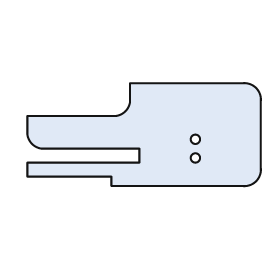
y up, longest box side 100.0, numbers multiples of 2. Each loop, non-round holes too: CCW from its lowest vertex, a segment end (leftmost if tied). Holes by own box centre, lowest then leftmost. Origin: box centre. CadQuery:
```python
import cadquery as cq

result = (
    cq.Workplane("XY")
    .moveTo(-14.0, -22.0)
    .lineTo(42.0, -22.0)
    .threePointArc((48.0, -20.0), (50.0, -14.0))
    .lineTo(50.0, 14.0)
    .threePointArc((48.0, 20.0), (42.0, 22.0))
    .lineTo(-6.0, 22.0)
    .lineTo(-6.0, 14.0)
    .threePointArc((-8.0, 10.0), (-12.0, 8.0))
    .lineTo(-50.0, 8.0)
    .lineTo(-50.0, 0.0)
    .threePointArc((-48.0, -4.0), (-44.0, -6.0))
    .lineTo(-2.0, -6.0)
    .lineTo(-2.0, -12.0)
    .lineTo(-50.0, -12.0)
    .lineTo(-50.0, -18.0)
    .lineTo(-14.0, -18.0)
    .close()
    .moveTo(22.0, -10.0)
    .circle(2.0)
    .moveTo(22.0, -2.0)
    .circle(2.0)
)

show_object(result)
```